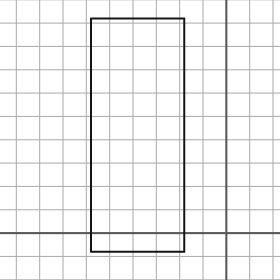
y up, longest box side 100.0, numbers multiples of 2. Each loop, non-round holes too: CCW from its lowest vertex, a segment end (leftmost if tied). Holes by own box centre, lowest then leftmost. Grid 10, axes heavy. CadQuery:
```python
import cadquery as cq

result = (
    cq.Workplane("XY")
    .moveTo(-58.0, -8.0)
    .lineTo(-18.0, -8.0)
    .lineTo(-18.0, 92.0)
    .lineTo(-58.0, 92.0)
    .close()
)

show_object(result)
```